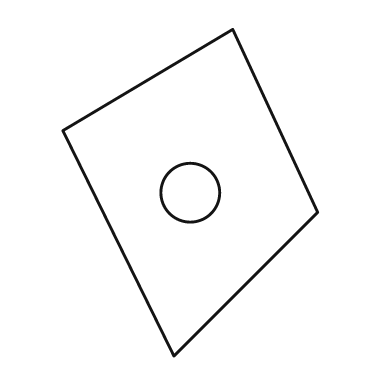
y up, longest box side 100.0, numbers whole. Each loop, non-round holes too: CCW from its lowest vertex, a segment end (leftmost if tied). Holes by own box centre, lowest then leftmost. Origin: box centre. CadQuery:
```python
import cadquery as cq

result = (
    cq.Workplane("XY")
    .moveTo(-5.0, -50.0)
    .lineTo(39.0, -6.0)
    .lineTo(13.0, 50.0)
    .lineTo(-39.0, 19.0)
    .close()
    .moveTo(0.0, 0.0)
    .circle(9.0)
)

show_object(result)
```